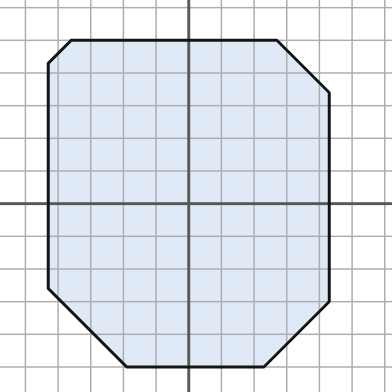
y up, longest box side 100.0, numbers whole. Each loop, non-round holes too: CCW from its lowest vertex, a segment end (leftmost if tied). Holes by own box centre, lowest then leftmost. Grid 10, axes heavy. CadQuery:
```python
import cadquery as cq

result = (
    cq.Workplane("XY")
    .moveTo(-19.0, -50.0)
    .lineTo(23.0, -50.0)
    .lineTo(43.0, -30.0)
    .lineTo(43.0, 34.0)
    .lineTo(27.0, 50.0)
    .lineTo(-36.0, 50.0)
    .lineTo(-43.0, 43.0)
    .lineTo(-43.0, -26.0)
    .close()
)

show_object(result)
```